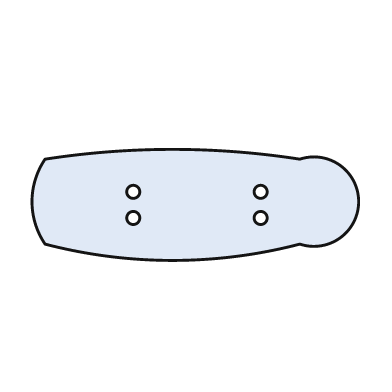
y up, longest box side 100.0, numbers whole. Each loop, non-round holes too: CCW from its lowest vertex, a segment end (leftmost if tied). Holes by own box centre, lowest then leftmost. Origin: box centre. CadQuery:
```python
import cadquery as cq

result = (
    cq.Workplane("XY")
    .moveTo(-46.0, -12.0)
    .threePointArc((-7.0, -17.0), (32.0, -12.0))
    .threePointArc((50.0, 1.0), (32.0, 14.0))
    .threePointArc((-7.0, 17.0), (-46.0, 14.0))
    .threePointArc((-50.0, 1.0), (-46.0, -12.0))
    .close()
    .moveTo(-19.0, -4.0)
    .circle(2.0)
    .moveTo(20.0, -4.0)
    .circle(2.0)
    .moveTo(-19.0, 4.0)
    .circle(2.0)
    .moveTo(20.0, 4.0)
    .circle(2.0)
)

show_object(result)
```